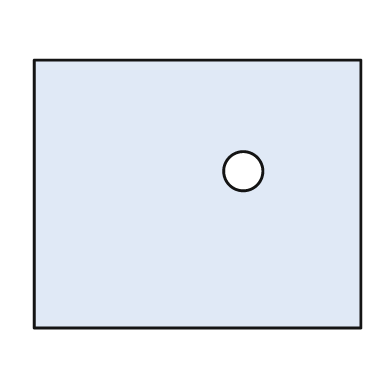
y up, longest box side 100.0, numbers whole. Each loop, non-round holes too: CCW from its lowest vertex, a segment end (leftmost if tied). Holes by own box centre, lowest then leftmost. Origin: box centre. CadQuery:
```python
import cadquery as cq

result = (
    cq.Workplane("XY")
    .moveTo(-50.0, -41.0)
    .lineTo(50.0, -41.0)
    .lineTo(50.0, 41.0)
    .lineTo(-50.0, 41.0)
    .close()
    .moveTo(14.0, 7.0)
    .circle(6.0)
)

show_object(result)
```